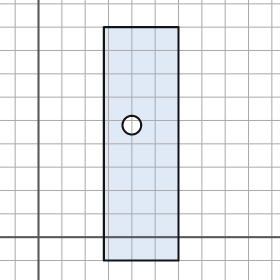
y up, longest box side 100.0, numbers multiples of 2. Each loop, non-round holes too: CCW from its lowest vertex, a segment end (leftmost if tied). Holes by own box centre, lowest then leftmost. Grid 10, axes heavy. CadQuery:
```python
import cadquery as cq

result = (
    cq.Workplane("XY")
    .moveTo(28.0, -10.0)
    .lineTo(60.0, -10.0)
    .lineTo(60.0, 90.0)
    .lineTo(28.0, 90.0)
    .close()
    .moveTo(40.0, 48.0)
    .circle(4.0)
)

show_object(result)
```